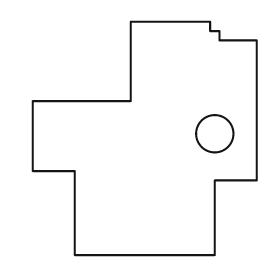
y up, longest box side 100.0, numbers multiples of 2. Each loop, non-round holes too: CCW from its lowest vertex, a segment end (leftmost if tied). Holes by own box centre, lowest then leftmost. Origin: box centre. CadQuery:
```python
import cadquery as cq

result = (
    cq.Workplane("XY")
    .moveTo(-30.0, -50.0)
    .lineTo(30.0, -50.0)
    .lineTo(30.0, -18.0)
    .lineTo(48.0, -18.0)
    .lineTo(48.0, 42.0)
    .lineTo(32.0, 42.0)
    .lineTo(32.0, 46.0)
    .lineTo(28.0, 46.0)
    .lineTo(28.0, 50.0)
    .lineTo(-6.0, 50.0)
    .lineTo(-6.0, 16.0)
    .lineTo(-48.0, 16.0)
    .lineTo(-48.0, -14.0)
    .lineTo(-30.0, -14.0)
    .close()
    .moveTo(30.0, 2.0)
    .circle(8.0)
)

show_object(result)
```